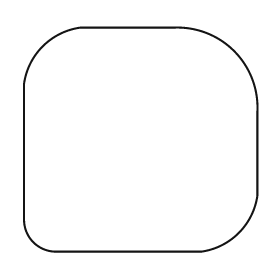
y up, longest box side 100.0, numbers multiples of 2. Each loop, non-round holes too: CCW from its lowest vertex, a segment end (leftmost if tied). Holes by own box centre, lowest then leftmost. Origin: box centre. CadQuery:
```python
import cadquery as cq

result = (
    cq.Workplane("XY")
    .moveTo(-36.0, -48.0)
    .lineTo(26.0, -48.0)
    .threePointArc((42.0, -40.0), (50.0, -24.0))
    .lineTo(50.0, 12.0)
    .threePointArc((40.0, 38.0), (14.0, 48.0))
    .lineTo(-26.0, 48.0)
    .threePointArc((-42.0, 40.0), (-50.0, 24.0))
    .lineTo(-50.0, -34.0)
    .threePointArc((-46.0, -44.0), (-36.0, -48.0))
    .close()
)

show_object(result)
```